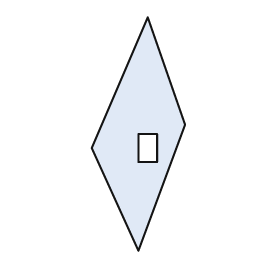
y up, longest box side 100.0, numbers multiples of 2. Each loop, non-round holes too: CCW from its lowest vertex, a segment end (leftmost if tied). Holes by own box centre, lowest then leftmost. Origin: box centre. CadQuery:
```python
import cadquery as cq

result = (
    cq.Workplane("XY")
    .moveTo(0.0, -50.0)
    .lineTo(20.0, 4.0)
    .lineTo(4.0, 50.0)
    .lineTo(-20.0, -6.0)
    .close()
    .moveTo(0.0, -12.0)
    .lineTo(8.0, -12.0)
    .lineTo(8.0, 0.0)
    .lineTo(0.0, 0.0)
    .close()
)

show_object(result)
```